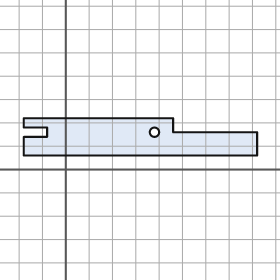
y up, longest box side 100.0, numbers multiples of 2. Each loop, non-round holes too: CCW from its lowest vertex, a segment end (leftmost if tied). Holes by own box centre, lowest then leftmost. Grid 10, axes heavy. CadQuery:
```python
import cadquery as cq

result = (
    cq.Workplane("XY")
    .moveTo(-18.0, 6.0)
    .lineTo(82.0, 6.0)
    .lineTo(82.0, 16.0)
    .lineTo(46.0, 16.0)
    .lineTo(46.0, 22.0)
    .lineTo(-18.0, 22.0)
    .lineTo(-18.0, 18.0)
    .lineTo(-8.0, 18.0)
    .lineTo(-8.0, 14.0)
    .lineTo(-18.0, 14.0)
    .close()
    .moveTo(38.0, 16.0)
    .circle(2.0)
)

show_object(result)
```